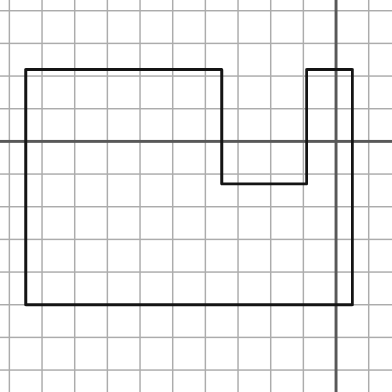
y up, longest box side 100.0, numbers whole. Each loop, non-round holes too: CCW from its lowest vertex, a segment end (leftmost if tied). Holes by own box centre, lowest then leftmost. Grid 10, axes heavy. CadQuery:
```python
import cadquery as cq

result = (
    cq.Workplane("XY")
    .moveTo(-95.0, -50.0)
    .lineTo(5.0, -50.0)
    .lineTo(5.0, 22.0)
    .lineTo(-9.0, 22.0)
    .lineTo(-9.0, -13.0)
    .lineTo(-35.0, -13.0)
    .lineTo(-35.0, 22.0)
    .lineTo(-95.0, 22.0)
    .close()
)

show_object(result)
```